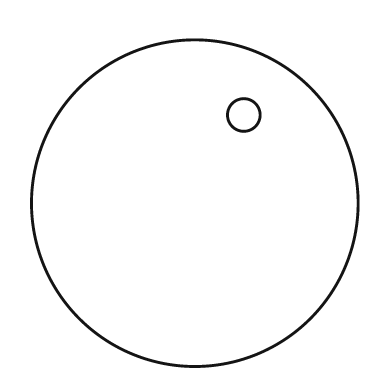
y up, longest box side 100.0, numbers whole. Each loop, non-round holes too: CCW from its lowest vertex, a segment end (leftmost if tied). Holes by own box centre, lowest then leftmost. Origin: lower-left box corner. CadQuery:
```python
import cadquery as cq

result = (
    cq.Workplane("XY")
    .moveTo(50.0, 50.0)
    .circle(50.0)
    .moveTo(65.0, 77.0)
    .circle(5.0)
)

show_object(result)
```